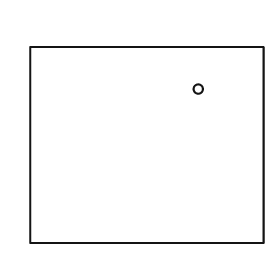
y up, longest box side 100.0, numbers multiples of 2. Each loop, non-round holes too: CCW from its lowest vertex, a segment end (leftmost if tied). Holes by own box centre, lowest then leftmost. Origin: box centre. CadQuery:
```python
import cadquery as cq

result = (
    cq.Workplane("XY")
    .moveTo(-50.0, -42.0)
    .lineTo(50.0, -42.0)
    .lineTo(50.0, 42.0)
    .lineTo(-50.0, 42.0)
    .close()
    .moveTo(22.0, 24.0)
    .circle(2.0)
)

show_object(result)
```